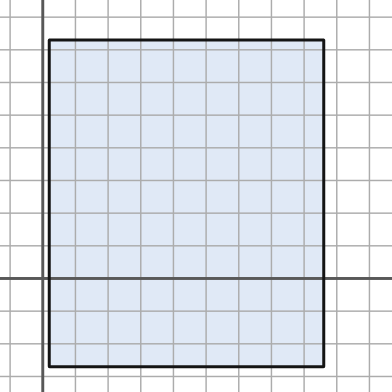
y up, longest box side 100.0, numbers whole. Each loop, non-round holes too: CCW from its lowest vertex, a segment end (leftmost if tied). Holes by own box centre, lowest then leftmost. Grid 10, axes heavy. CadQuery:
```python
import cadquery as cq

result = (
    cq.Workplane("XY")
    .moveTo(2.0, -27.0)
    .lineTo(86.0, -27.0)
    .lineTo(86.0, 73.0)
    .lineTo(2.0, 73.0)
    .close()
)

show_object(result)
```